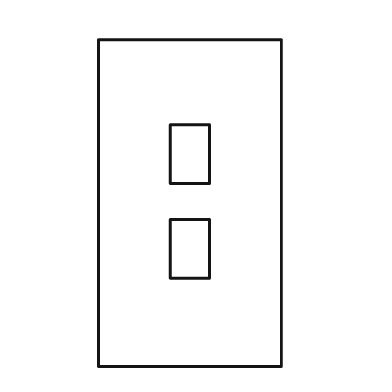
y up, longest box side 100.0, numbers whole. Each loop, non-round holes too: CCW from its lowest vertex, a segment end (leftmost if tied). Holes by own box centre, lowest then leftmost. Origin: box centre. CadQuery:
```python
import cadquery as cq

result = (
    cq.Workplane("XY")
    .moveTo(-28.0, -50.0)
    .lineTo(28.0, -50.0)
    .lineTo(28.0, 50.0)
    .lineTo(-28.0, 50.0)
    .close()
    .moveTo(-6.0, -23.0)
    .lineTo(6.0, -23.0)
    .lineTo(6.0, -5.0)
    .lineTo(-6.0, -5.0)
    .close()
    .moveTo(-6.0, 6.0)
    .lineTo(6.0, 6.0)
    .lineTo(6.0, 24.0)
    .lineTo(-6.0, 24.0)
    .close()
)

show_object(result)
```